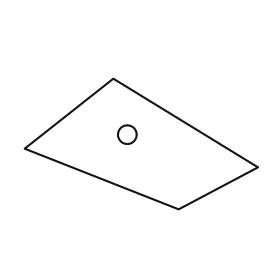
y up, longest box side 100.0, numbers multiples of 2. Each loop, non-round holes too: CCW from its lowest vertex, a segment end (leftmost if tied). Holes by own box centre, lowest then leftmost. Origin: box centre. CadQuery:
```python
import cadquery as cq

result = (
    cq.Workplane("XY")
    .moveTo(16.0, -28.0)
    .lineTo(50.0, -10.0)
    .lineTo(-12.0, 28.0)
    .lineTo(-50.0, -2.0)
    .close()
    .moveTo(-6.0, 4.0)
    .circle(4.0)
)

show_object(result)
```